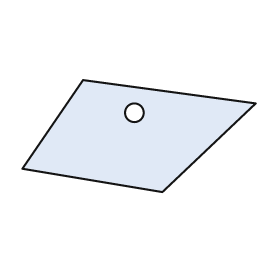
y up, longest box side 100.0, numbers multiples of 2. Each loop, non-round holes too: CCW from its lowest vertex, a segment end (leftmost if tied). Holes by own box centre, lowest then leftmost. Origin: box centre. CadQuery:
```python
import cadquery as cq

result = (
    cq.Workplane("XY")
    .moveTo(10.0, -24.0)
    .lineTo(50.0, 14.0)
    .lineTo(-24.0, 24.0)
    .lineTo(-50.0, -14.0)
    .close()
    .moveTo(-2.0, 10.0)
    .circle(4.0)
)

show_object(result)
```